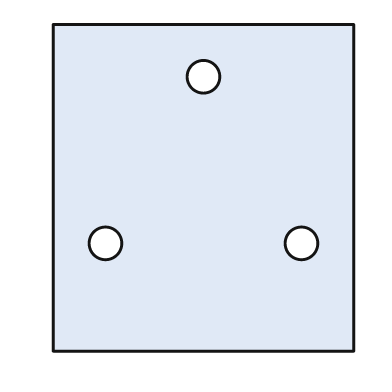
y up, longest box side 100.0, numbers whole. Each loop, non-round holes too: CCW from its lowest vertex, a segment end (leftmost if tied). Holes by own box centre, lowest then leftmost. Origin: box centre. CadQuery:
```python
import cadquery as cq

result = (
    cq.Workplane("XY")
    .moveTo(-46.0, -50.0)
    .lineTo(46.0, -50.0)
    .lineTo(46.0, 50.0)
    .lineTo(-46.0, 50.0)
    .close()
    .moveTo(-30.0, -17.0)
    .circle(5.0)
    .moveTo(30.0, -17.0)
    .circle(5.0)
    .moveTo(0.0, 34.0)
    .circle(5.0)
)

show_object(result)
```